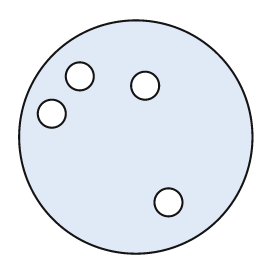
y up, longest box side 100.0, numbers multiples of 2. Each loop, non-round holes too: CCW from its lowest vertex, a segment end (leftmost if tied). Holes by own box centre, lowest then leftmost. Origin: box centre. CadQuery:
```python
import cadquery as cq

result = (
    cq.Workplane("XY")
    .moveTo(0.0, 0.0)
    .circle(50.0)
    .moveTo(14.0, -28.0)
    .circle(6.0)
    .moveTo(-36.0, 10.0)
    .circle(6.0)
    .moveTo(4.0, 22.0)
    .circle(6.0)
    .moveTo(-24.0, 26.0)
    .circle(6.0)
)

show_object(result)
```